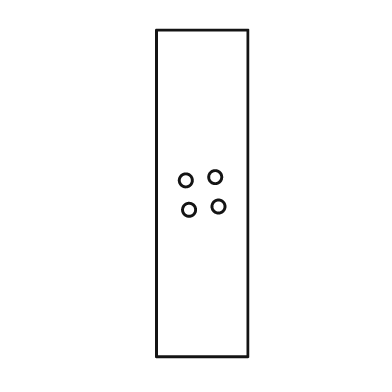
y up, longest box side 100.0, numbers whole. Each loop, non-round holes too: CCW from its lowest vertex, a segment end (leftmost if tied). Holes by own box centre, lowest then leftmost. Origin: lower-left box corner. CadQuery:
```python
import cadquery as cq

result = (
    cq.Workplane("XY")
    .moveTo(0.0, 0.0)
    .lineTo(28.0, 0.0)
    .lineTo(28.0, 100.0)
    .lineTo(0.0, 100.0)
    .close()
    .moveTo(10.0, 45.0)
    .circle(2.0)
    .moveTo(19.0, 46.0)
    .circle(2.0)
    .moveTo(9.0, 54.0)
    .circle(2.0)
    .moveTo(18.0, 55.0)
    .circle(2.0)
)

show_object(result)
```